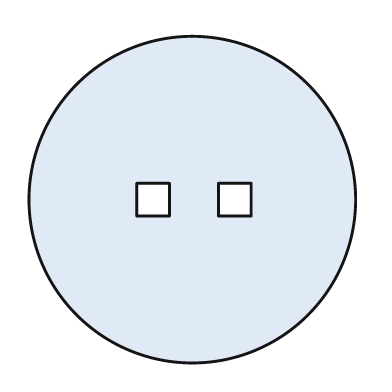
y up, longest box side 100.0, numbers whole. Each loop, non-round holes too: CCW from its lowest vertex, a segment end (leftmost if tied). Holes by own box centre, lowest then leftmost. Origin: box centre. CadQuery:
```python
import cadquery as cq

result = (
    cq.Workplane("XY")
    .moveTo(0.0, 0.0)
    .circle(50.0)
    .moveTo(-17.0, -5.0)
    .lineTo(-7.0, -5.0)
    .lineTo(-7.0, 5.0)
    .lineTo(-17.0, 5.0)
    .close()
    .moveTo(8.0, -5.0)
    .lineTo(18.0, -5.0)
    .lineTo(18.0, 5.0)
    .lineTo(8.0, 5.0)
    .close()
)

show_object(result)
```